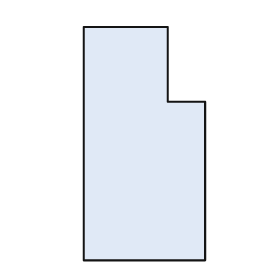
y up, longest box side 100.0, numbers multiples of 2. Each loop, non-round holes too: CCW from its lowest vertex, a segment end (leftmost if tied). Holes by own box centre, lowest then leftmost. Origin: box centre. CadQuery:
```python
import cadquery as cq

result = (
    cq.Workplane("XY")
    .moveTo(-26.0, -50.0)
    .lineTo(26.0, -50.0)
    .lineTo(26.0, 18.0)
    .lineTo(10.0, 18.0)
    .lineTo(10.0, 50.0)
    .lineTo(-26.0, 50.0)
    .close()
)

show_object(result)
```